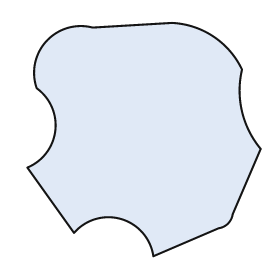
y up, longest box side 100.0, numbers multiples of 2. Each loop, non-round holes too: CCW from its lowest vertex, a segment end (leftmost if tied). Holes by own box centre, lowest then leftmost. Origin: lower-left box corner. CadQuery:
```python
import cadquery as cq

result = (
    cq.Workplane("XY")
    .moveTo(54.0, 0.0)
    .lineTo(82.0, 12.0)
    .threePointArc((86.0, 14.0), (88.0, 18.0))
    .lineTo(100.0, 46.0)
    .threePointArc((92.0, 62.0), (92.0, 80.0))
    .threePointArc((80.0, 94.0), (62.0, 100.0))
    .lineTo(28.0, 98.0)
    .threePointArc((8.0, 92.0), (4.0, 72.0))
    .threePointArc((12.0, 54.0), (0.0, 38.0))
    .lineTo(20.0, 10.0)
    .threePointArc((40.0, 16.0), (54.0, 0.0))
    .close()
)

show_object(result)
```